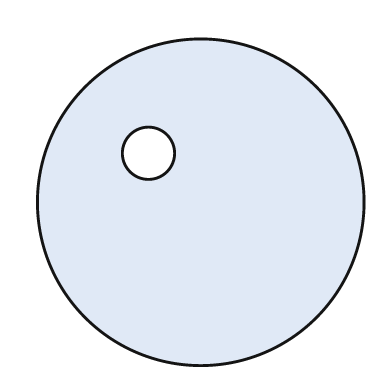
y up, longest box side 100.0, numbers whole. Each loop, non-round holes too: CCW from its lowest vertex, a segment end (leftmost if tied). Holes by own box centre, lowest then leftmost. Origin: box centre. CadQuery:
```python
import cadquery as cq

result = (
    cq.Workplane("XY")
    .moveTo(0.0, 0.0)
    .circle(50.0)
    .moveTo(-16.0, 15.0)
    .circle(8.0)
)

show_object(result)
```